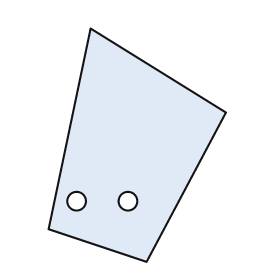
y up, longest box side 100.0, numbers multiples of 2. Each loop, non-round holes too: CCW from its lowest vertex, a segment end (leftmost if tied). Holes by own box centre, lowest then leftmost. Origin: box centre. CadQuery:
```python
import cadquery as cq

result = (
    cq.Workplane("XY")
    .moveTo(4.0, -50.0)
    .lineTo(38.0, 14.0)
    .lineTo(-20.0, 50.0)
    .lineTo(-38.0, -36.0)
    .close()
    .moveTo(-26.0, -24.0)
    .circle(4.0)
    .moveTo(-4.0, -24.0)
    .circle(4.0)
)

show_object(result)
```